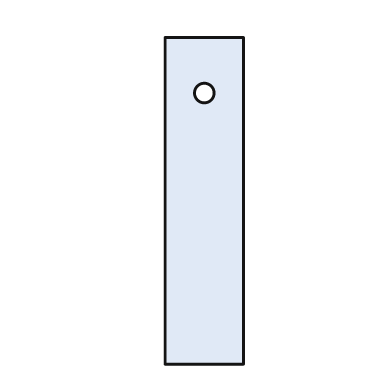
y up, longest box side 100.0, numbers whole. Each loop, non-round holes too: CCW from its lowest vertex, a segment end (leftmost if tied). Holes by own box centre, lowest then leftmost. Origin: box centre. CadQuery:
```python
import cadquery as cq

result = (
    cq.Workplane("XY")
    .moveTo(-12.0, -50.0)
    .lineTo(12.0, -50.0)
    .lineTo(12.0, 50.0)
    .lineTo(-12.0, 50.0)
    .close()
    .moveTo(0.0, 33.0)
    .circle(3.0)
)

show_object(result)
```